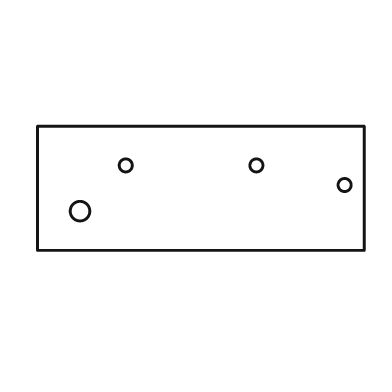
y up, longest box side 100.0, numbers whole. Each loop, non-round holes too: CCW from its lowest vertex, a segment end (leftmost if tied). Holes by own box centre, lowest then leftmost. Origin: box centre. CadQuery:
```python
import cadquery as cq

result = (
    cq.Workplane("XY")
    .moveTo(-50.0, -19.0)
    .lineTo(50.0, -19.0)
    .lineTo(50.0, 19.0)
    .lineTo(-50.0, 19.0)
    .close()
    .moveTo(-37.0, -7.0)
    .circle(3.0)
    .moveTo(44.0, 1.0)
    .circle(2.0)
    .moveTo(-23.0, 7.0)
    .circle(2.0)
    .moveTo(17.0, 7.0)
    .circle(2.0)
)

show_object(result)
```